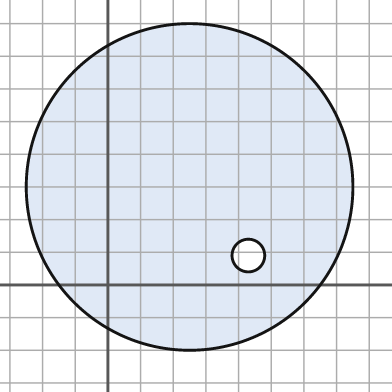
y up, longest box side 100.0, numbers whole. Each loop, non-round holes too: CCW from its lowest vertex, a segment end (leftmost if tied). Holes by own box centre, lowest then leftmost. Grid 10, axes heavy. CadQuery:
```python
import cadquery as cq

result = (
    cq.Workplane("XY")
    .moveTo(25.0, 30.0)
    .circle(50.0)
    .moveTo(43.0, 9.0)
    .circle(5.0)
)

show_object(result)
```